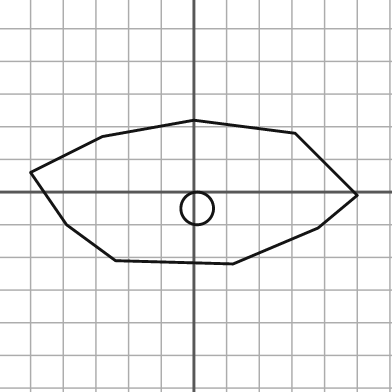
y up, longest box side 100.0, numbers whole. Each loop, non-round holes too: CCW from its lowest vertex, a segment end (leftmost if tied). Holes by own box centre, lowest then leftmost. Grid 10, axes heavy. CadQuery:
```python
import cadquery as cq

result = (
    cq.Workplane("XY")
    .moveTo(12.0, -22.0)
    .lineTo(38.0, -11.0)
    .lineTo(50.0, -1.0)
    .lineTo(31.0, 18.0)
    .lineTo(0.0, 22.0)
    .lineTo(-28.0, 17.0)
    .lineTo(-50.0, 6.0)
    .lineTo(-39.0, -10.0)
    .lineTo(-24.0, -21.0)
    .close()
    .moveTo(1.0, -5.0)
    .circle(5.0)
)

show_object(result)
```